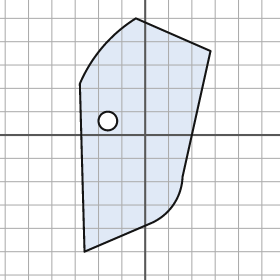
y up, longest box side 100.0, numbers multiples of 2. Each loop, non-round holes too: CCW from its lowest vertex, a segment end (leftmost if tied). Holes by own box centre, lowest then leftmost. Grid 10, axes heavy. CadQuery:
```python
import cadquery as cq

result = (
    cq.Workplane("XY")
    .moveTo(-26.0, -50.0)
    .lineTo(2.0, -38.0)
    .threePointArc((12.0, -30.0), (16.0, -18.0))
    .lineTo(28.0, 36.0)
    .lineTo(-4.0, 50.0)
    .threePointArc((-18.0, 38.0), (-28.0, 22.0))
    .close()
    .moveTo(-16.0, 6.0)
    .circle(4.0)
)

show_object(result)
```